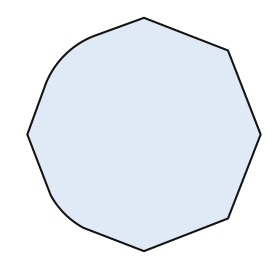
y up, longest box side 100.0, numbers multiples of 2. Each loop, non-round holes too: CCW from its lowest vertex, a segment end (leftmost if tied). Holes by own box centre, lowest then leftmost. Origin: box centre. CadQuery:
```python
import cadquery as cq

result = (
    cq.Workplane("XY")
    .moveTo(0.0, -50.0)
    .lineTo(36.0, -36.0)
    .lineTo(50.0, 0.0)
    .lineTo(36.0, 36.0)
    .lineTo(0.0, 50.0)
    .lineTo(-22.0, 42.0)
    .threePointArc((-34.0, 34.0), (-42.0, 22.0))
    .lineTo(-50.0, 0.0)
    .lineTo(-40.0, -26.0)
    .threePointArc((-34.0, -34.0), (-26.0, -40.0))
    .close()
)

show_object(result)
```